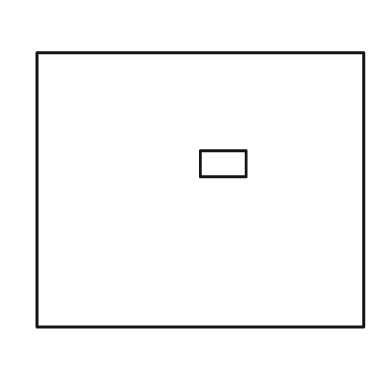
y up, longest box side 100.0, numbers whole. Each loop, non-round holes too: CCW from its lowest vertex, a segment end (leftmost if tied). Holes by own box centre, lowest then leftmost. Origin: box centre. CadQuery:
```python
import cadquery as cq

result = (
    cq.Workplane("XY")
    .moveTo(-50.0, -42.0)
    .lineTo(50.0, -42.0)
    .lineTo(50.0, 42.0)
    .lineTo(-50.0, 42.0)
    .close()
    .moveTo(0.0, 4.0)
    .lineTo(14.0, 4.0)
    .lineTo(14.0, 12.0)
    .lineTo(0.0, 12.0)
    .close()
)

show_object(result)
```